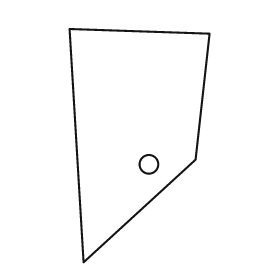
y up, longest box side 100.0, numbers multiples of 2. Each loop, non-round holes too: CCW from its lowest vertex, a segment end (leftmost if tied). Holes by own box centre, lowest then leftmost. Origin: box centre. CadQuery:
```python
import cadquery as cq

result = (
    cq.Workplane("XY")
    .moveTo(-24.0, -50.0)
    .lineTo(24.0, -6.0)
    .lineTo(30.0, 48.0)
    .lineTo(-30.0, 50.0)
    .close()
    .moveTo(4.0, -8.0)
    .circle(4.0)
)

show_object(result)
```